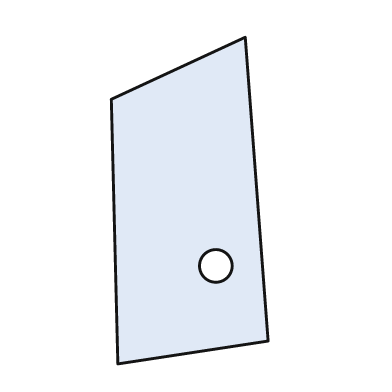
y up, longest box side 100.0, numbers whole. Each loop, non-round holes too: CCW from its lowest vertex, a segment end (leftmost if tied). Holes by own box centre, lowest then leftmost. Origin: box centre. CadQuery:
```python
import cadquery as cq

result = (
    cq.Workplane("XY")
    .moveTo(-22.0, -50.0)
    .lineTo(24.0, -43.0)
    .lineTo(17.0, 50.0)
    .lineTo(-24.0, 31.0)
    .close()
    .moveTo(8.0, -20.0)
    .circle(5.0)
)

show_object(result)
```